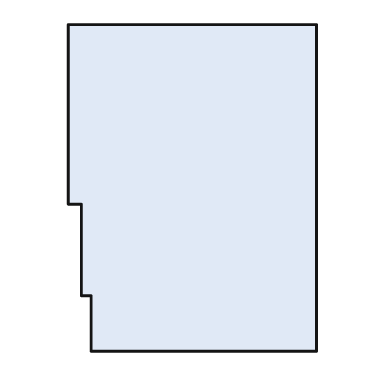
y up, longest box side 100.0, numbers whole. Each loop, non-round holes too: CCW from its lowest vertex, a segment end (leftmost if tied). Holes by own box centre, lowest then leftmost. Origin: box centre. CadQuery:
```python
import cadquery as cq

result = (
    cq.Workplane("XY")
    .moveTo(-31.0, -50.0)
    .lineTo(38.0, -50.0)
    .lineTo(38.0, 50.0)
    .lineTo(-38.0, 50.0)
    .lineTo(-38.0, -5.0)
    .lineTo(-34.0, -5.0)
    .lineTo(-34.0, -33.0)
    .lineTo(-31.0, -33.0)
    .close()
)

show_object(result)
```